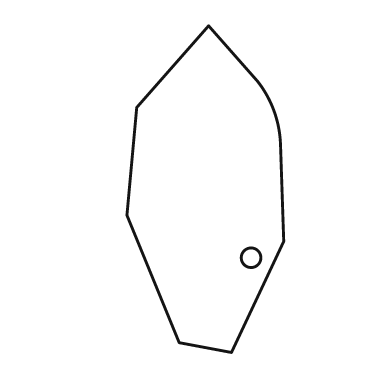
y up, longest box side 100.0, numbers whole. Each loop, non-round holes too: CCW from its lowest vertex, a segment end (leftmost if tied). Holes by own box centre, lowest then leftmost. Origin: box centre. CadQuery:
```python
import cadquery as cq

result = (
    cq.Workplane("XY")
    .moveTo(8.0, -50.0)
    .lineTo(24.0, -16.0)
    .lineTo(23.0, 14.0)
    .threePointArc((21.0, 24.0), (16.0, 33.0))
    .lineTo(1.0, 50.0)
    .lineTo(-21.0, 25.0)
    .lineTo(-24.0, -8.0)
    .lineTo(-8.0, -47.0)
    .close()
    .moveTo(14.0, -21.0)
    .circle(3.0)
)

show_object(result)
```